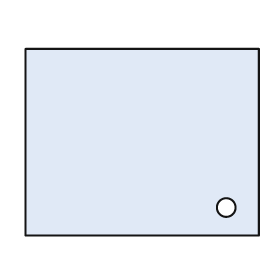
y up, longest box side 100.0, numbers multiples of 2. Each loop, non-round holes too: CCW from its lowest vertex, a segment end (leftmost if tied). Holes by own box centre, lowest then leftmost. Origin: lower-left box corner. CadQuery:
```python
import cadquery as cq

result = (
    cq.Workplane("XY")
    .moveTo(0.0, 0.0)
    .lineTo(100.0, 0.0)
    .lineTo(100.0, 80.0)
    .lineTo(0.0, 80.0)
    .close()
    .moveTo(86.0, 12.0)
    .circle(4.0)
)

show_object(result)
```